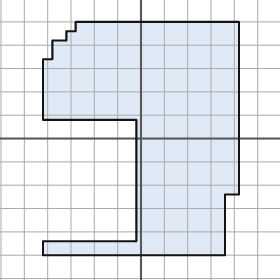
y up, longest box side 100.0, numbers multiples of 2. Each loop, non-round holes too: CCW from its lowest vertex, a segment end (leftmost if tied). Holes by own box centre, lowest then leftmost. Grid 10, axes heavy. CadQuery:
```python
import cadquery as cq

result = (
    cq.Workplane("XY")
    .moveTo(-42.0, -50.0)
    .lineTo(36.0, -50.0)
    .lineTo(36.0, -24.0)
    .lineTo(42.0, -24.0)
    .lineTo(42.0, 50.0)
    .lineTo(-28.0, 50.0)
    .lineTo(-28.0, 46.0)
    .lineTo(-32.0, 46.0)
    .lineTo(-32.0, 42.0)
    .lineTo(-38.0, 42.0)
    .lineTo(-38.0, 34.0)
    .lineTo(-42.0, 34.0)
    .lineTo(-42.0, 8.0)
    .lineTo(-2.0, 8.0)
    .lineTo(-2.0, -44.0)
    .lineTo(-42.0, -44.0)
    .close()
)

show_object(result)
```